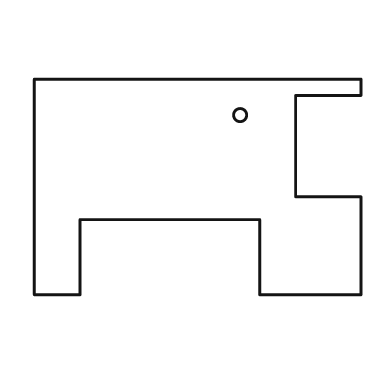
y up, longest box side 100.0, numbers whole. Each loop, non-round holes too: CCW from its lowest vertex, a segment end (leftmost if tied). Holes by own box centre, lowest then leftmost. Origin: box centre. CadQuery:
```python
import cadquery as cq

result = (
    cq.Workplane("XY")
    .moveTo(-50.0, -33.0)
    .lineTo(-36.0, -33.0)
    .lineTo(-36.0, -10.0)
    .lineTo(19.0, -10.0)
    .lineTo(19.0, -33.0)
    .lineTo(50.0, -33.0)
    .lineTo(50.0, -3.0)
    .lineTo(30.0, -3.0)
    .lineTo(30.0, 28.0)
    .lineTo(50.0, 28.0)
    .lineTo(50.0, 33.0)
    .lineTo(-50.0, 33.0)
    .close()
    .moveTo(13.0, 22.0)
    .circle(2.0)
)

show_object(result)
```